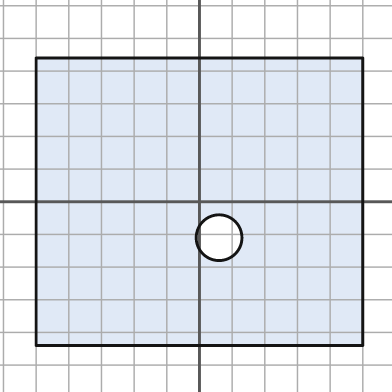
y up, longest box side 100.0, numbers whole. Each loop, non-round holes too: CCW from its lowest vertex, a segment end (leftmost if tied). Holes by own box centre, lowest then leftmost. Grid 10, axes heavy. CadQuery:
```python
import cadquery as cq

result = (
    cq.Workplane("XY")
    .moveTo(-50.0, -44.0)
    .lineTo(50.0, -44.0)
    .lineTo(50.0, 44.0)
    .lineTo(-50.0, 44.0)
    .close()
    .moveTo(6.0, -11.0)
    .circle(7.0)
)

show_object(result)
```